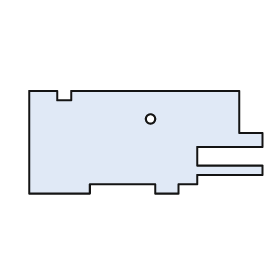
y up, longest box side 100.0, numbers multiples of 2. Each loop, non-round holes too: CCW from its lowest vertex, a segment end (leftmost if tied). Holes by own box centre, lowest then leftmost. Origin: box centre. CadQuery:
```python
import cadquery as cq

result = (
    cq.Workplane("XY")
    .moveTo(-50.0, -22.0)
    .lineTo(-24.0, -22.0)
    .lineTo(-24.0, -18.0)
    .lineTo(4.0, -18.0)
    .lineTo(4.0, -22.0)
    .lineTo(14.0, -22.0)
    .lineTo(14.0, -18.0)
    .lineTo(22.0, -18.0)
    .lineTo(22.0, -14.0)
    .lineTo(50.0, -14.0)
    .lineTo(50.0, -10.0)
    .lineTo(22.0, -10.0)
    .lineTo(22.0, -2.0)
    .lineTo(50.0, -2.0)
    .lineTo(50.0, 4.0)
    .lineTo(40.0, 4.0)
    .lineTo(40.0, 22.0)
    .lineTo(-32.0, 22.0)
    .lineTo(-32.0, 18.0)
    .lineTo(-38.0, 18.0)
    .lineTo(-38.0, 22.0)
    .lineTo(-50.0, 22.0)
    .close()
    .moveTo(2.0, 10.0)
    .circle(2.0)
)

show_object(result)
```